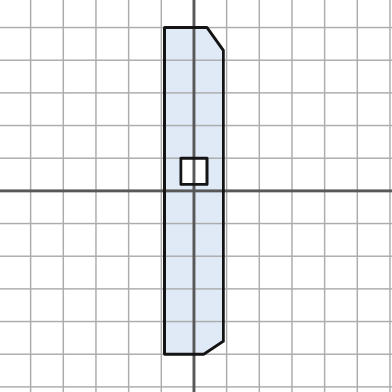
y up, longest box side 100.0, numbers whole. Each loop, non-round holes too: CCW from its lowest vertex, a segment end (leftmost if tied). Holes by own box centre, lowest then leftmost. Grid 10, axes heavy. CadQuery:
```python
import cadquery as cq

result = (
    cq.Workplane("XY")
    .moveTo(-9.0, -50.0)
    .lineTo(3.0, -50.0)
    .lineTo(9.0, -46.0)
    .lineTo(9.0, 43.0)
    .lineTo(4.0, 50.0)
    .lineTo(-9.0, 50.0)
    .close()
    .moveTo(-4.0, 2.0)
    .lineTo(4.0, 2.0)
    .lineTo(4.0, 10.0)
    .lineTo(-4.0, 10.0)
    .close()
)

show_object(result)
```